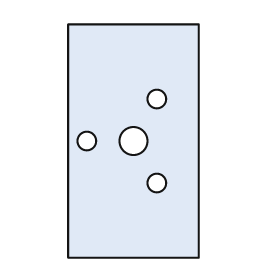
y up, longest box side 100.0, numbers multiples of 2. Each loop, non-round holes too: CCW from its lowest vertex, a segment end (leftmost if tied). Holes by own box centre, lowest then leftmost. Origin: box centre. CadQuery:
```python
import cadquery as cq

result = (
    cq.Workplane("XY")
    .moveTo(-28.0, -50.0)
    .lineTo(28.0, -50.0)
    .lineTo(28.0, 50.0)
    .lineTo(-28.0, 50.0)
    .close()
    .moveTo(10.0, -18.0)
    .circle(4.0)
    .moveTo(-20.0, 0.0)
    .circle(4.0)
    .moveTo(0.0, 0.0)
    .circle(6.0)
    .moveTo(10.0, 18.0)
    .circle(4.0)
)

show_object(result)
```